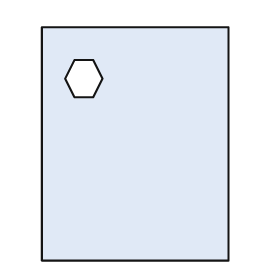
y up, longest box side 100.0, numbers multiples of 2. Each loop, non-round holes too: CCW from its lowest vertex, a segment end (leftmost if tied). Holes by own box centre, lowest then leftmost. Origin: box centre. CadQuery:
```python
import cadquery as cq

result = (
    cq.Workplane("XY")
    .moveTo(-40.0, -50.0)
    .lineTo(40.0, -50.0)
    .lineTo(40.0, 50.0)
    .lineTo(-40.0, 50.0)
    .close()
    .moveTo(-26.0, 20.0)
    .lineTo(-18.0, 20.0)
    .lineTo(-14.0, 28.0)
    .lineTo(-18.0, 36.0)
    .lineTo(-26.0, 36.0)
    .lineTo(-30.0, 28.0)
    .close()
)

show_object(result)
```